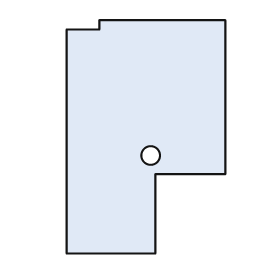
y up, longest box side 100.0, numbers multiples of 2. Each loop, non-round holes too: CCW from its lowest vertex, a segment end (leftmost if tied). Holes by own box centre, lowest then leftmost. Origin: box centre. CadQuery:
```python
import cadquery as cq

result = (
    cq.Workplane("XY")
    .moveTo(-34.0, -50.0)
    .lineTo(4.0, -50.0)
    .lineTo(4.0, -16.0)
    .lineTo(34.0, -16.0)
    .lineTo(34.0, 50.0)
    .lineTo(-20.0, 50.0)
    .lineTo(-20.0, 46.0)
    .lineTo(-34.0, 46.0)
    .close()
    .moveTo(2.0, -8.0)
    .circle(4.0)
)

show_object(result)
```